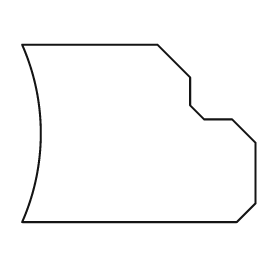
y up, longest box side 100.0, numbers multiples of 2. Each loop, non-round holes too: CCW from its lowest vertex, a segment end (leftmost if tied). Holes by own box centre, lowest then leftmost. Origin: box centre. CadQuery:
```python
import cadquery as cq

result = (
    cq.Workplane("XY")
    .moveTo(-50.0, -38.0)
    .lineTo(42.0, -38.0)
    .lineTo(50.0, -30.0)
    .lineTo(50.0, -4.0)
    .lineTo(40.0, 6.0)
    .lineTo(28.0, 6.0)
    .lineTo(22.0, 12.0)
    .lineTo(22.0, 24.0)
    .lineTo(8.0, 38.0)
    .lineTo(-50.0, 38.0)
    .threePointArc((-42.0, 0.0), (-50.0, -38.0))
    .close()
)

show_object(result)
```